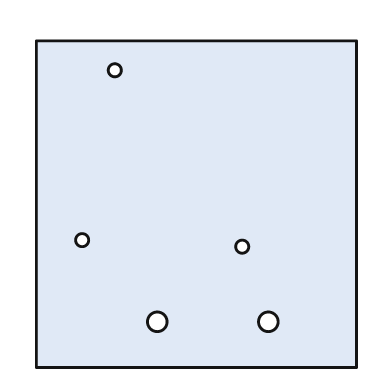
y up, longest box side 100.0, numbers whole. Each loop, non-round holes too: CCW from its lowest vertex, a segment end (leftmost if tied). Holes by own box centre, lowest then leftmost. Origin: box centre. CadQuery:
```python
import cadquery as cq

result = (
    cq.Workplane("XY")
    .moveTo(-49.0, -50.0)
    .lineTo(49.0, -50.0)
    .lineTo(49.0, 50.0)
    .lineTo(-49.0, 50.0)
    .close()
    .moveTo(-12.0, -36.0)
    .circle(3.0)
    .moveTo(22.0, -36.0)
    .circle(3.0)
    .moveTo(14.0, -13.0)
    .circle(2.0)
    .moveTo(-35.0, -11.0)
    .circle(2.0)
    .moveTo(-25.0, 41.0)
    .circle(2.0)
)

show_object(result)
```